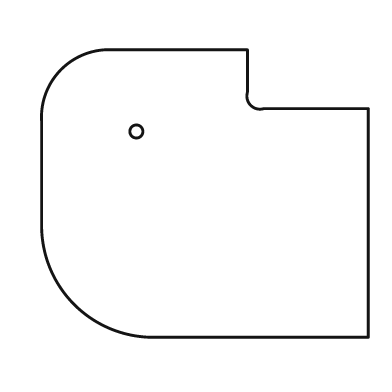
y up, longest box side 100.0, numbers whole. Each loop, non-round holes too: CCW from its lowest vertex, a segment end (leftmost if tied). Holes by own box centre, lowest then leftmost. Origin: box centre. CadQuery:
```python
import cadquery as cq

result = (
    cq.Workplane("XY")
    .moveTo(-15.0, -44.0)
    .lineTo(50.0, -44.0)
    .lineTo(50.0, 26.0)
    .lineTo(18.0, 26.0)
    .threePointArc((14.0, 27.0), (13.0, 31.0))
    .lineTo(13.0, 44.0)
    .lineTo(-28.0, 44.0)
    .threePointArc((-44.0, 38.0), (-50.0, 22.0))
    .lineTo(-50.0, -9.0)
    .threePointArc((-40.0, -34.0), (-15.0, -44.0))
    .close()
    .moveTo(-21.0, 19.0)
    .circle(2.0)
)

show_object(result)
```